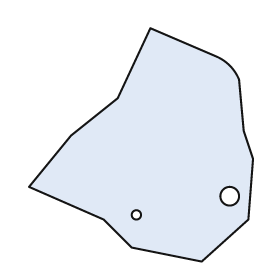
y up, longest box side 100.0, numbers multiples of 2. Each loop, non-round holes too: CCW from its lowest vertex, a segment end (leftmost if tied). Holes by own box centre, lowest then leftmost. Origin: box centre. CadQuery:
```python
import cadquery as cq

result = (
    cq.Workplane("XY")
    .moveTo(26.0, -50.0)
    .lineTo(46.0, -32.0)
    .lineTo(48.0, -6.0)
    .lineTo(44.0, 6.0)
    .lineTo(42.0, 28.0)
    .threePointArc((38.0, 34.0), (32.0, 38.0))
    .lineTo(4.0, 50.0)
    .lineTo(-10.0, 20.0)
    .lineTo(-30.0, 4.0)
    .lineTo(-48.0, -18.0)
    .lineTo(-16.0, -32.0)
    .lineTo(-4.0, -44.0)
    .close()
    .moveTo(-2.0, -30.0)
    .circle(2.0)
    .moveTo(38.0, -22.0)
    .circle(4.0)
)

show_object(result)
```